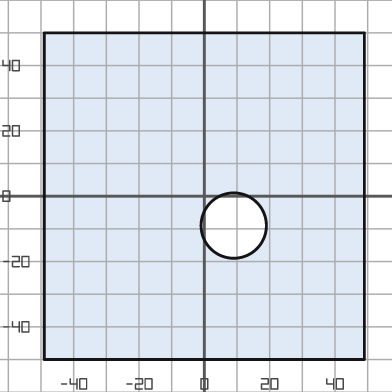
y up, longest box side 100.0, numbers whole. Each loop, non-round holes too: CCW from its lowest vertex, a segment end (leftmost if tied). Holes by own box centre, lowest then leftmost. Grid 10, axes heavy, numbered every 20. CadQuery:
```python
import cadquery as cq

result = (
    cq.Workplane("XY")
    .moveTo(-49.0, -50.0)
    .lineTo(49.0, -50.0)
    .lineTo(49.0, 50.0)
    .lineTo(-49.0, 50.0)
    .close()
    .moveTo(9.0, -9.0)
    .circle(10.0)
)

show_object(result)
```